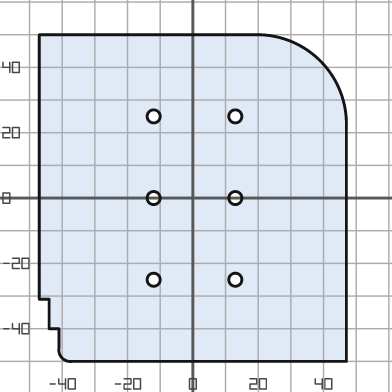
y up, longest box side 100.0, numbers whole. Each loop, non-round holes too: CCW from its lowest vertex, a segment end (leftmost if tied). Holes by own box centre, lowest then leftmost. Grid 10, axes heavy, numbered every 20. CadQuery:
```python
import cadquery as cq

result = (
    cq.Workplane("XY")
    .moveTo(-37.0, -50.0)
    .lineTo(47.0, -50.0)
    .lineTo(47.0, 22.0)
    .threePointArc((39.0, 42.0), (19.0, 50.0))
    .lineTo(-47.0, 50.0)
    .lineTo(-47.0, -31.0)
    .lineTo(-44.0, -31.0)
    .lineTo(-44.0, -40.0)
    .lineTo(-41.0, -40.0)
    .lineTo(-41.0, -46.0)
    .threePointArc((-40.0, -49.0), (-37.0, -50.0))
    .close()
    .moveTo(-12.0, -25.0)
    .circle(2.0)
    .moveTo(13.0, -25.0)
    .circle(2.0)
    .moveTo(-12.0, 0.0)
    .circle(2.0)
    .moveTo(13.0, 0.0)
    .circle(2.0)
    .moveTo(-12.0, 25.0)
    .circle(2.0)
    .moveTo(13.0, 25.0)
    .circle(2.0)
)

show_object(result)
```